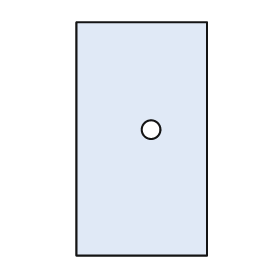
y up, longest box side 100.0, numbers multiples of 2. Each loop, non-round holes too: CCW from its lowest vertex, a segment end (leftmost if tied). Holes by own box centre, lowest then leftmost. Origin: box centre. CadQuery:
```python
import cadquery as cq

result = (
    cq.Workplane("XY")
    .moveTo(-28.0, -50.0)
    .lineTo(28.0, -50.0)
    .lineTo(28.0, 50.0)
    .lineTo(-28.0, 50.0)
    .close()
    .moveTo(4.0, 4.0)
    .circle(4.0)
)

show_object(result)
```